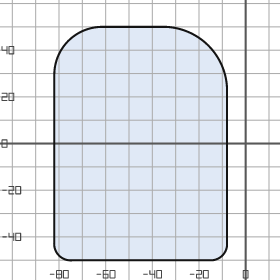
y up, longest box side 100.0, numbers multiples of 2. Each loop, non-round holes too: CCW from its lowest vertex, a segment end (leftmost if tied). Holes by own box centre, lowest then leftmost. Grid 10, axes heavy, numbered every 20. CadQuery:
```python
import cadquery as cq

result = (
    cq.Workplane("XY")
    .moveTo(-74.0, -50.0)
    .lineTo(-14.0, -50.0)
    .threePointArc((-10.0, -48.0), (-8.0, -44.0))
    .lineTo(-8.0, 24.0)
    .threePointArc((-16.0, 42.0), (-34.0, 50.0))
    .lineTo(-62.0, 50.0)
    .threePointArc((-76.0, 44.0), (-82.0, 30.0))
    .lineTo(-82.0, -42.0)
    .threePointArc((-80.0, -48.0), (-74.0, -50.0))
    .close()
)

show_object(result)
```